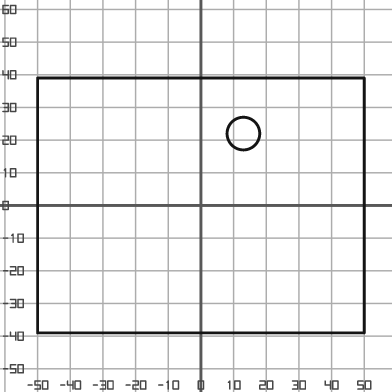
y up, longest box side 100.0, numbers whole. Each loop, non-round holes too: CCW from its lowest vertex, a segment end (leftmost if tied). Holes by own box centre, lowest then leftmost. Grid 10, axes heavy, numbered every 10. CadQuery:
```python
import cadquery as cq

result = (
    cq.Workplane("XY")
    .moveTo(-50.0, -39.0)
    .lineTo(50.0, -39.0)
    .lineTo(50.0, 39.0)
    .lineTo(-50.0, 39.0)
    .close()
    .moveTo(13.0, 22.0)
    .circle(5.0)
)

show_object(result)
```